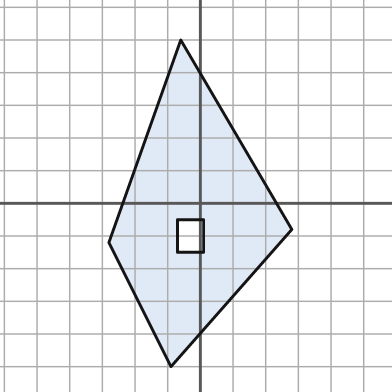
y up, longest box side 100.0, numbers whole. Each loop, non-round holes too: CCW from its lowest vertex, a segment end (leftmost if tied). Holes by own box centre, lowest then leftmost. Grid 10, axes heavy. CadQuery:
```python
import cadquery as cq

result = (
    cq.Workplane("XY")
    .moveTo(-9.0, -50.0)
    .lineTo(28.0, -8.0)
    .lineTo(-6.0, 50.0)
    .lineTo(-28.0, -12.0)
    .close()
    .moveTo(-7.0, -15.0)
    .lineTo(1.0, -15.0)
    .lineTo(1.0, -5.0)
    .lineTo(-7.0, -5.0)
    .close()
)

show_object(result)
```